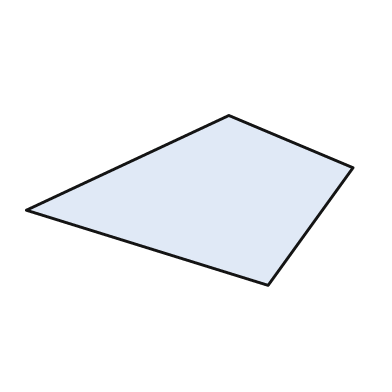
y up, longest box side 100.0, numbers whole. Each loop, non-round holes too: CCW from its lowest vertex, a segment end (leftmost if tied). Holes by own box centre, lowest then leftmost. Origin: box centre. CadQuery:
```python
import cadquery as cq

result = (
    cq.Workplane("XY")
    .moveTo(24.0, -26.0)
    .lineTo(50.0, 10.0)
    .lineTo(12.0, 26.0)
    .lineTo(-50.0, -3.0)
    .close()
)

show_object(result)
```